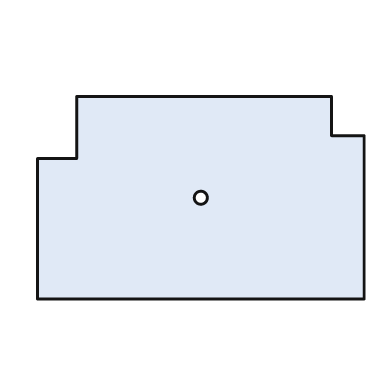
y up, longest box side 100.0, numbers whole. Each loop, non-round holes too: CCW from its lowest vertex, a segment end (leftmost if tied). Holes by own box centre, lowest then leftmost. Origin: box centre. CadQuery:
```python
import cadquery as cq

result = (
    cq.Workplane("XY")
    .moveTo(-50.0, -31.0)
    .lineTo(50.0, -31.0)
    .lineTo(50.0, 19.0)
    .lineTo(40.0, 19.0)
    .lineTo(40.0, 31.0)
    .lineTo(-38.0, 31.0)
    .lineTo(-38.0, 12.0)
    .lineTo(-50.0, 12.0)
    .close()
    .moveTo(0.0, 0.0)
    .circle(2.0)
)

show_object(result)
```